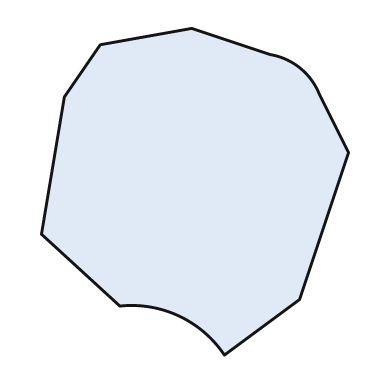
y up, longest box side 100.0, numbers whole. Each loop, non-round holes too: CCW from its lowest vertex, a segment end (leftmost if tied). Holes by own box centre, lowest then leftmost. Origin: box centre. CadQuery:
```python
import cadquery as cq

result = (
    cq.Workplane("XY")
    .moveTo(9.0, -50.0)
    .lineTo(32.0, -33.0)
    .lineTo(47.0, 12.0)
    .lineTo(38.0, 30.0)
    .threePointArc((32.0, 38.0), (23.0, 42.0))
    .lineTo(-1.0, 50.0)
    .lineTo(-29.0, 45.0)
    .lineTo(-40.0, 29.0)
    .lineTo(-47.0, -13.0)
    .lineTo(-23.0, -35.0)
    .threePointArc((-5.0, -38.0), (9.0, -50.0))
    .close()
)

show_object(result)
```